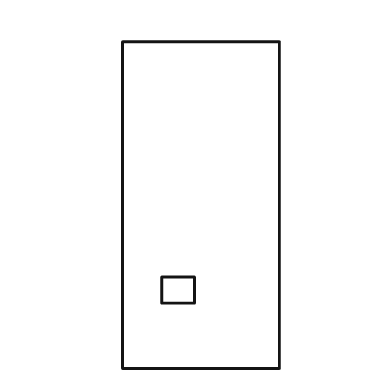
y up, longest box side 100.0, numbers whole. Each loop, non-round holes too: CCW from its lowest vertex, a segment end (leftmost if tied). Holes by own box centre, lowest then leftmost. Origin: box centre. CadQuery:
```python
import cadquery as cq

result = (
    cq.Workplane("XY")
    .moveTo(-24.0, -50.0)
    .lineTo(24.0, -50.0)
    .lineTo(24.0, 50.0)
    .lineTo(-24.0, 50.0)
    .close()
    .moveTo(-12.0, -30.0)
    .lineTo(-2.0, -30.0)
    .lineTo(-2.0, -22.0)
    .lineTo(-12.0, -22.0)
    .close()
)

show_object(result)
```